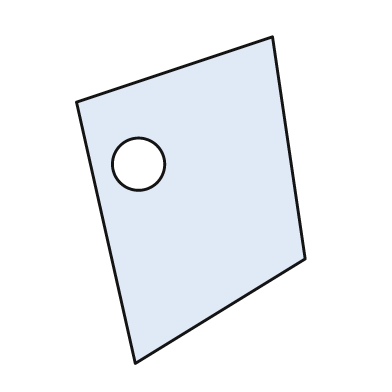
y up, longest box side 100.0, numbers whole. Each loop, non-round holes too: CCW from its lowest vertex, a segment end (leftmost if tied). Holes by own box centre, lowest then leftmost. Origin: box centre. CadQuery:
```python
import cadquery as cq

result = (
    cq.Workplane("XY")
    .moveTo(-17.0, -50.0)
    .lineTo(35.0, -18.0)
    .lineTo(25.0, 50.0)
    .lineTo(-35.0, 30.0)
    .close()
    .moveTo(-16.0, 11.0)
    .circle(8.0)
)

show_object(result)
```